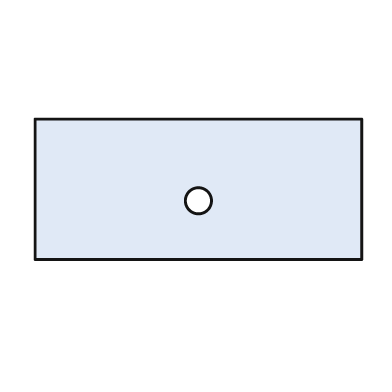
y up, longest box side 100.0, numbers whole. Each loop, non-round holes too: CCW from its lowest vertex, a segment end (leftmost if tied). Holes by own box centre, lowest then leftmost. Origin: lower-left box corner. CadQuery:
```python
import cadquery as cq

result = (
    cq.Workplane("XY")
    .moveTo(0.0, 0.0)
    .lineTo(100.0, 0.0)
    .lineTo(100.0, 43.0)
    .lineTo(0.0, 43.0)
    .close()
    .moveTo(50.0, 18.0)
    .circle(4.0)
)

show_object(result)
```